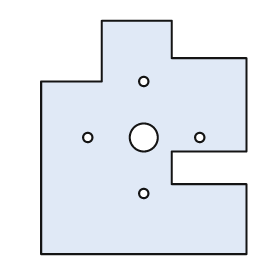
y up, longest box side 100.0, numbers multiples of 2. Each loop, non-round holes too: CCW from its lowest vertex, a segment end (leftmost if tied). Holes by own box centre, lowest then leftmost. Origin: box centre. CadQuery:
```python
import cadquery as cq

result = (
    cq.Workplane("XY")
    .moveTo(-44.0, -50.0)
    .lineTo(44.0, -50.0)
    .lineTo(44.0, -20.0)
    .lineTo(12.0, -20.0)
    .lineTo(12.0, -6.0)
    .lineTo(44.0, -6.0)
    .lineTo(44.0, 34.0)
    .lineTo(12.0, 34.0)
    .lineTo(12.0, 50.0)
    .lineTo(-18.0, 50.0)
    .lineTo(-18.0, 24.0)
    .lineTo(-44.0, 24.0)
    .close()
    .moveTo(0.0, -24.0)
    .circle(2.0)
    .moveTo(-24.0, 0.0)
    .circle(2.0)
    .moveTo(0.0, 0.0)
    .circle(6.0)
    .moveTo(24.0, 0.0)
    .circle(2.0)
    .moveTo(0.0, 24.0)
    .circle(2.0)
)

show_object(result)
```